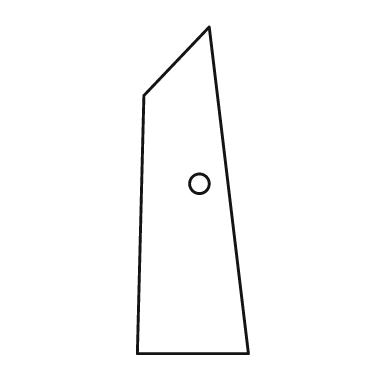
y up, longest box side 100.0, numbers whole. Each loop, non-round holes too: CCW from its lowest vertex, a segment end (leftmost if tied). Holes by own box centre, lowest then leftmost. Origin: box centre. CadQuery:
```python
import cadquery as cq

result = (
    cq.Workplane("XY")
    .moveTo(-17.0, -50.0)
    .lineTo(17.0, -50.0)
    .lineTo(5.0, 50.0)
    .lineTo(-15.0, 29.0)
    .close()
    .moveTo(2.0, 2.0)
    .circle(3.0)
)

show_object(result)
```